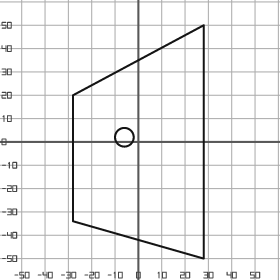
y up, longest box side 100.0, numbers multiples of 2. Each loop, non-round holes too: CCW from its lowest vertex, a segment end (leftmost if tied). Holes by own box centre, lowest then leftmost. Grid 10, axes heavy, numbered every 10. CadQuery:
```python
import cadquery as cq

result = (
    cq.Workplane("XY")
    .moveTo(28.0, -50.0)
    .lineTo(28.0, 50.0)
    .lineTo(-28.0, 20.0)
    .lineTo(-28.0, -34.0)
    .close()
    .moveTo(-6.0, 2.0)
    .circle(4.0)
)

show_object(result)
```